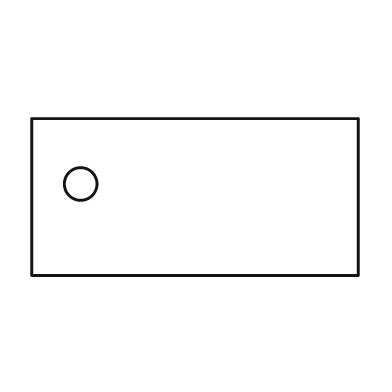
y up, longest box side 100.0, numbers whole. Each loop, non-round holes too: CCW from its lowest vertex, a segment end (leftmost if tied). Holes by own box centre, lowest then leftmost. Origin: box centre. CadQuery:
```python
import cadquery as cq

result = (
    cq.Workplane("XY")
    .moveTo(-50.0, -24.0)
    .lineTo(50.0, -24.0)
    .lineTo(50.0, 24.0)
    .lineTo(-50.0, 24.0)
    .close()
    .moveTo(-35.0, 4.0)
    .circle(5.0)
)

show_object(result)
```